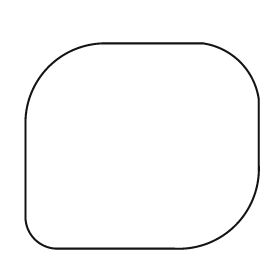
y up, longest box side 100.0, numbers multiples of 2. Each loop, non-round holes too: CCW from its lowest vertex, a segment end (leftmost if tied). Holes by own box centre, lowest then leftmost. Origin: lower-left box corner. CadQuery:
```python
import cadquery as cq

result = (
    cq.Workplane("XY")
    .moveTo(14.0, 0.0)
    .lineTo(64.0, 0.0)
    .threePointArc((90.0, 10.0), (100.0, 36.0))
    .lineTo(100.0, 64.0)
    .threePointArc((92.0, 80.0), (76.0, 88.0))
    .lineTo(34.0, 88.0)
    .threePointArc((10.0, 78.0), (0.0, 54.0))
    .lineTo(0.0, 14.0)
    .threePointArc((4.0, 4.0), (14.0, 0.0))
    .close()
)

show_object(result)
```